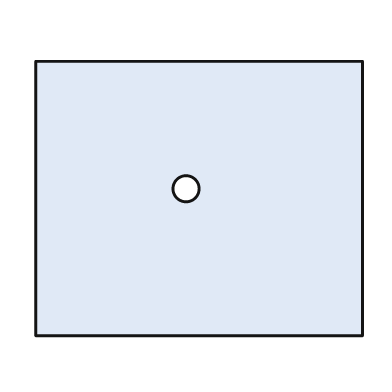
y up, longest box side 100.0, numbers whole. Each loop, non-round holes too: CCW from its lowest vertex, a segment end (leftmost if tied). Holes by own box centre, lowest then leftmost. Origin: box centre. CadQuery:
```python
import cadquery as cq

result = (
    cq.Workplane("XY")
    .moveTo(-50.0, -42.0)
    .lineTo(50.0, -42.0)
    .lineTo(50.0, 42.0)
    .lineTo(-50.0, 42.0)
    .close()
    .moveTo(-4.0, 3.0)
    .circle(4.0)
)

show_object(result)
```